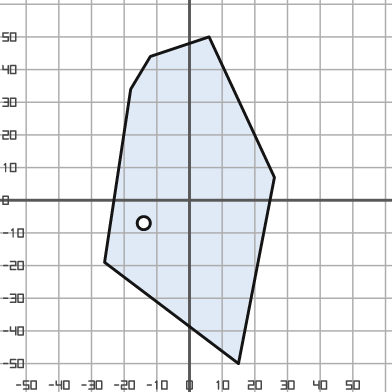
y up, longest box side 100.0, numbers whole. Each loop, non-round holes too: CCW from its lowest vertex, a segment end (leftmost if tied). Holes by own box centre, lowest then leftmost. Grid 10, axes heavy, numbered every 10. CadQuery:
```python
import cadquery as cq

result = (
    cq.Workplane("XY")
    .moveTo(15.0, -50.0)
    .lineTo(26.0, 7.0)
    .lineTo(6.0, 50.0)
    .lineTo(-12.0, 44.0)
    .lineTo(-18.0, 34.0)
    .lineTo(-26.0, -19.0)
    .close()
    .moveTo(-14.0, -7.0)
    .circle(2.0)
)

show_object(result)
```